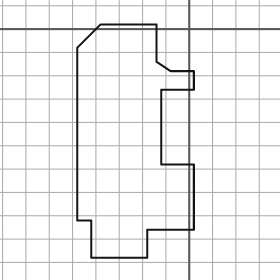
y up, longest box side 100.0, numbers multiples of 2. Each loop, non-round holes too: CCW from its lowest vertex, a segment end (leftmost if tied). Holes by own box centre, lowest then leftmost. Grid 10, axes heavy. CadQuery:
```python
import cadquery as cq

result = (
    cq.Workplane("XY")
    .moveTo(-42.0, -98.0)
    .lineTo(-18.0, -98.0)
    .lineTo(-18.0, -86.0)
    .lineTo(2.0, -86.0)
    .lineTo(2.0, -58.0)
    .lineTo(-12.0, -58.0)
    .lineTo(-12.0, -26.0)
    .lineTo(2.0, -26.0)
    .lineTo(2.0, -18.0)
    .lineTo(-8.0, -18.0)
    .lineTo(-14.0, -14.0)
    .lineTo(-14.0, 2.0)
    .lineTo(-38.0, 2.0)
    .lineTo(-48.0, -8.0)
    .lineTo(-48.0, -82.0)
    .lineTo(-42.0, -82.0)
    .close()
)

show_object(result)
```